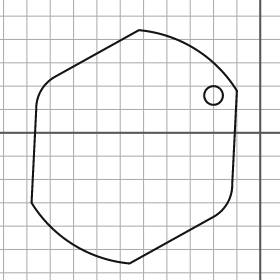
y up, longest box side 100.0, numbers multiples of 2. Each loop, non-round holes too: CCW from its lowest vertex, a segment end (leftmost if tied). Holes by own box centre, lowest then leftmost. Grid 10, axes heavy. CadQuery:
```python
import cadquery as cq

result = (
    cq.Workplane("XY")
    .moveTo(-56.0, -56.0)
    .lineTo(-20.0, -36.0)
    .threePointArc((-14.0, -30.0), (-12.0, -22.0))
    .lineTo(-10.0, 18.0)
    .threePointArc((-28.0, 36.0), (-52.0, 44.0))
    .lineTo(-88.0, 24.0)
    .threePointArc((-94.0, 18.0), (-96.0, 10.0))
    .lineTo(-98.0, -30.0)
    .threePointArc((-80.0, -48.0), (-56.0, -56.0))
    .close()
    .moveTo(-20.0, 16.0)
    .circle(4.0)
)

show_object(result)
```